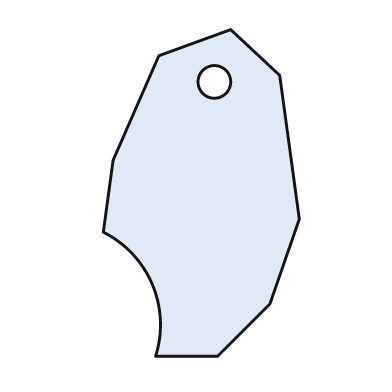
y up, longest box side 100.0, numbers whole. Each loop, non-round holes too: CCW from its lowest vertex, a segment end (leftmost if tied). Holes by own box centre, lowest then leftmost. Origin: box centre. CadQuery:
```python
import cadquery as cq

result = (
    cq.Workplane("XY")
    .moveTo(-14.0, -50.0)
    .lineTo(5.0, -50.0)
    .lineTo(21.0, -34.0)
    .lineTo(30.0, -8.0)
    .lineTo(24.0, 36.0)
    .lineTo(9.0, 50.0)
    .lineTo(-13.0, 42.0)
    .lineTo(-27.0, 10.0)
    .lineTo(-30.0, -12.0)
    .threePointArc((-15.0, -28.0), (-14.0, -50.0))
    .close()
    .moveTo(4.0, 34.0)
    .circle(5.0)
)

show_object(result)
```